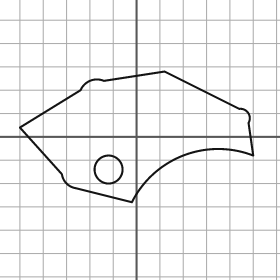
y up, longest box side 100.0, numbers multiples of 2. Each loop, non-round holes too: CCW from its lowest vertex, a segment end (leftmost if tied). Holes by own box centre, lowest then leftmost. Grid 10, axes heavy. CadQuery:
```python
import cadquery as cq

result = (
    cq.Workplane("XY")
    .moveTo(-2.0, -28.0)
    .threePointArc((20.0, -8.0), (50.0, -8.0))
    .lineTo(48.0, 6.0)
    .threePointArc((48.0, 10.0), (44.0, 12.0))
    .lineTo(12.0, 28.0)
    .lineTo(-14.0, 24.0)
    .threePointArc((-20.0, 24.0), (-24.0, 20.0))
    .lineTo(-50.0, 4.0)
    .lineTo(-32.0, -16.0)
    .threePointArc((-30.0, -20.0), (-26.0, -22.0))
    .close()
    .moveTo(-12.0, -14.0)
    .circle(6.0)
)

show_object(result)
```